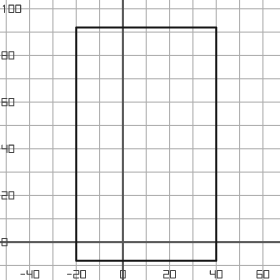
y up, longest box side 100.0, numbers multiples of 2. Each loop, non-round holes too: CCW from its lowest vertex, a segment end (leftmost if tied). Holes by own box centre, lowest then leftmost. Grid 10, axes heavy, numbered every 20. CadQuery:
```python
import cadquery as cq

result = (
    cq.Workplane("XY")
    .moveTo(-20.0, -8.0)
    .lineTo(40.0, -8.0)
    .lineTo(40.0, 92.0)
    .lineTo(-20.0, 92.0)
    .close()
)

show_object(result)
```